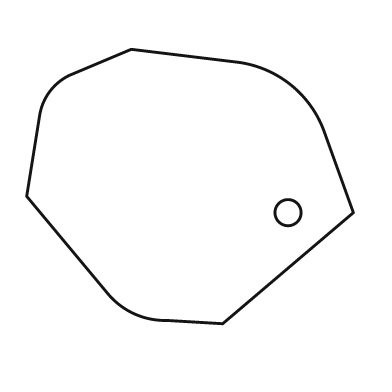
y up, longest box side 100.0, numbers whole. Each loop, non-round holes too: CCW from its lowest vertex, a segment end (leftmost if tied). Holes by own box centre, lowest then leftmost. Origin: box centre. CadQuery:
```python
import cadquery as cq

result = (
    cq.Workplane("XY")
    .moveTo(10.0, -42.0)
    .lineTo(50.0, -8.0)
    .lineTo(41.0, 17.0)
    .threePointArc((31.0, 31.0), (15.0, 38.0))
    .lineTo(-18.0, 42.0)
    .lineTo(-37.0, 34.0)
    .threePointArc((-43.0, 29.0), (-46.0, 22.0))
    .lineTo(-50.0, -3.0)
    .lineTo(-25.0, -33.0)
    .threePointArc((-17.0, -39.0), (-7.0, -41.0))
    .close()
    .moveTo(30.0, -8.0)
    .circle(4.0)
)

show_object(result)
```